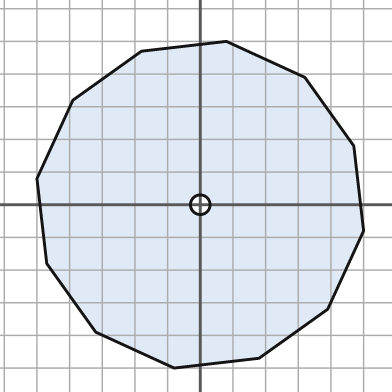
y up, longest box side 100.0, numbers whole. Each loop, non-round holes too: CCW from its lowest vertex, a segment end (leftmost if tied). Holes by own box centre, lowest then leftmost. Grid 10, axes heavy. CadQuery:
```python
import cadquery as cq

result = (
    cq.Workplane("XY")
    .moveTo(-8.0, -50.0)
    .lineTo(18.0, -47.0)
    .lineTo(39.0, -32.0)
    .lineTo(50.0, -8.0)
    .lineTo(47.0, 18.0)
    .lineTo(32.0, 39.0)
    .lineTo(8.0, 50.0)
    .lineTo(-18.0, 47.0)
    .lineTo(-39.0, 32.0)
    .lineTo(-50.0, 8.0)
    .lineTo(-47.0, -18.0)
    .lineTo(-32.0, -39.0)
    .close()
    .moveTo(0.0, 0.0)
    .circle(3.0)
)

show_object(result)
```